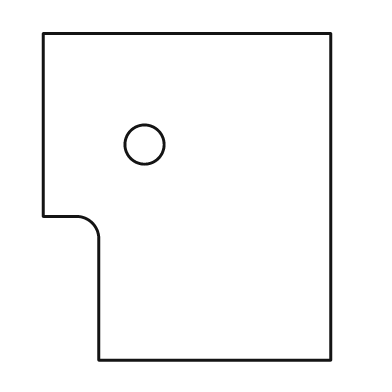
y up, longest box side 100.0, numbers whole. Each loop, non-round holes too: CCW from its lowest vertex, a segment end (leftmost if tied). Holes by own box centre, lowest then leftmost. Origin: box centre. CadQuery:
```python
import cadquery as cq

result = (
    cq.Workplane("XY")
    .moveTo(-27.0, -50.0)
    .lineTo(44.0, -50.0)
    .lineTo(44.0, 50.0)
    .lineTo(-44.0, 50.0)
    .lineTo(-44.0, -6.0)
    .lineTo(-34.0, -6.0)
    .threePointArc((-29.0, -8.0), (-27.0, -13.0))
    .close()
    .moveTo(-13.0, 16.0)
    .circle(6.0)
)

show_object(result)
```